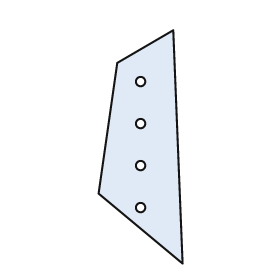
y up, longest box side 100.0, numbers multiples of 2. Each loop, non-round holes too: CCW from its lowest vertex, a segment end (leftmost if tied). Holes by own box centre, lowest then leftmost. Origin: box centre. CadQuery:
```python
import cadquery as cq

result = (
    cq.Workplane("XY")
    .moveTo(18.0, -50.0)
    .lineTo(14.0, 50.0)
    .lineTo(-10.0, 36.0)
    .lineTo(-18.0, -20.0)
    .close()
    .moveTo(0.0, -26.0)
    .circle(2.0)
    .moveTo(0.0, -8.0)
    .circle(2.0)
    .moveTo(0.0, 10.0)
    .circle(2.0)
    .moveTo(0.0, 28.0)
    .circle(2.0)
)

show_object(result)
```